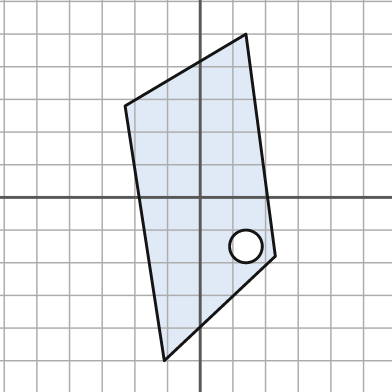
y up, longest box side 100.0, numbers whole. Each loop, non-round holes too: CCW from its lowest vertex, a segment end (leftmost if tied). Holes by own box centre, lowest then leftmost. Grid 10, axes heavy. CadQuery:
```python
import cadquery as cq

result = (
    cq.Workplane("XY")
    .moveTo(-11.0, -50.0)
    .lineTo(23.0, -18.0)
    .lineTo(14.0, 50.0)
    .lineTo(-23.0, 28.0)
    .close()
    .moveTo(14.0, -15.0)
    .circle(5.0)
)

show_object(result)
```